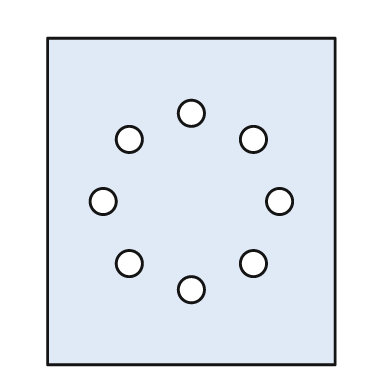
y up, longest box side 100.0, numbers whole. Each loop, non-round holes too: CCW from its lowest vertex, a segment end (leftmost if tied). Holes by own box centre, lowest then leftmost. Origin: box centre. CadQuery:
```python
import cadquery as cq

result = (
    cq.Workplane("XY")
    .moveTo(-44.0, -50.0)
    .lineTo(44.0, -50.0)
    .lineTo(44.0, 50.0)
    .lineTo(-44.0, 50.0)
    .close()
    .moveTo(0.0, -27.0)
    .circle(4.0)
    .moveTo(-19.0, -19.0)
    .circle(4.0)
    .moveTo(19.0, -19.0)
    .circle(4.0)
    .moveTo(-27.0, 0.0)
    .circle(4.0)
    .moveTo(27.0, 0.0)
    .circle(4.0)
    .moveTo(-19.0, 19.0)
    .circle(4.0)
    .moveTo(19.0, 19.0)
    .circle(4.0)
    .moveTo(0.0, 27.0)
    .circle(4.0)
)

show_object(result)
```